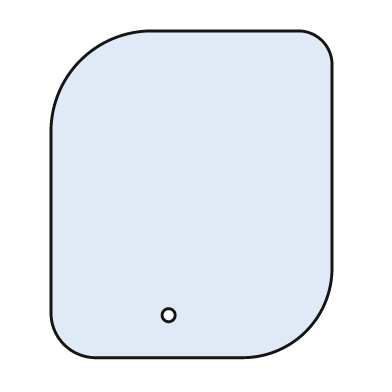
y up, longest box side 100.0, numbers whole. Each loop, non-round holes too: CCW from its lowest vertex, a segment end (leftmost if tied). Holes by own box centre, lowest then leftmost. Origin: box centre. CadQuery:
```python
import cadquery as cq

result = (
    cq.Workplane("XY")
    .moveTo(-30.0, -50.0)
    .lineTo(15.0, -50.0)
    .threePointArc((35.0, -42.0), (43.0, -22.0))
    .lineTo(43.0, 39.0)
    .threePointArc((40.0, 47.0), (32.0, 50.0))
    .lineTo(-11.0, 50.0)
    .threePointArc((-34.0, 41.0), (-43.0, 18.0))
    .lineTo(-43.0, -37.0)
    .threePointArc((-39.0, -46.0), (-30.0, -50.0))
    .close()
    .moveTo(-7.0, -37.0)
    .circle(2.0)
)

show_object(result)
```